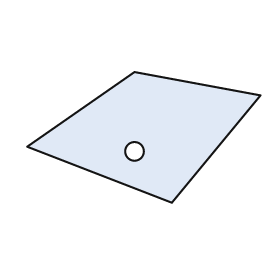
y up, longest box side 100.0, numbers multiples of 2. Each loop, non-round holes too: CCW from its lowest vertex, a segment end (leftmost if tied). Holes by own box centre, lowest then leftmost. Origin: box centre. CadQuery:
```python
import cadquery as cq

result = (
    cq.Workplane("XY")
    .moveTo(12.0, -28.0)
    .lineTo(50.0, 18.0)
    .lineTo(-4.0, 28.0)
    .lineTo(-50.0, -4.0)
    .close()
    .moveTo(-4.0, -6.0)
    .circle(4.0)
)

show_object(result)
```